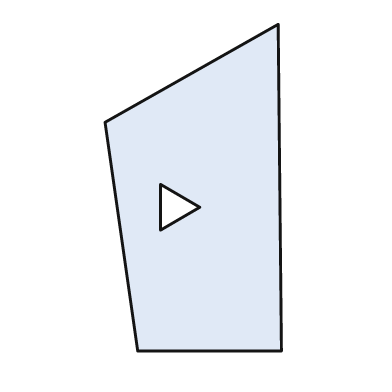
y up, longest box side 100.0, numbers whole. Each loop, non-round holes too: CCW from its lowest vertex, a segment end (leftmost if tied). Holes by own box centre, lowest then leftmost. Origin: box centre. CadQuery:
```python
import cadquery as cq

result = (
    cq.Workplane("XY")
    .moveTo(-17.0, -50.0)
    .lineTo(27.0, -50.0)
    .lineTo(26.0, 50.0)
    .lineTo(-27.0, 20.0)
    .close()
    .moveTo(-10.0, -13.0)
    .lineTo(2.0, -6.0)
    .lineTo(-10.0, 1.0)
    .close()
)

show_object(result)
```